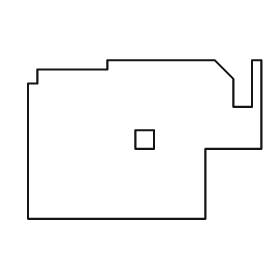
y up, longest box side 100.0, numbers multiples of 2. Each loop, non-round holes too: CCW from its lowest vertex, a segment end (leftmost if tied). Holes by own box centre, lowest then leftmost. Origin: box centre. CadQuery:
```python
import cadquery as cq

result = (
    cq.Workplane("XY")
    .moveTo(-50.0, -34.0)
    .lineTo(26.0, -34.0)
    .lineTo(26.0, -4.0)
    .lineTo(50.0, -4.0)
    .lineTo(50.0, 34.0)
    .lineTo(46.0, 34.0)
    .lineTo(46.0, 14.0)
    .lineTo(38.0, 14.0)
    .lineTo(38.0, 26.0)
    .lineTo(30.0, 34.0)
    .lineTo(-16.0, 34.0)
    .lineTo(-16.0, 30.0)
    .lineTo(-46.0, 30.0)
    .lineTo(-46.0, 24.0)
    .lineTo(-50.0, 24.0)
    .close()
    .moveTo(-4.0, -4.0)
    .lineTo(4.0, -4.0)
    .lineTo(4.0, 4.0)
    .lineTo(-4.0, 4.0)
    .close()
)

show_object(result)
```